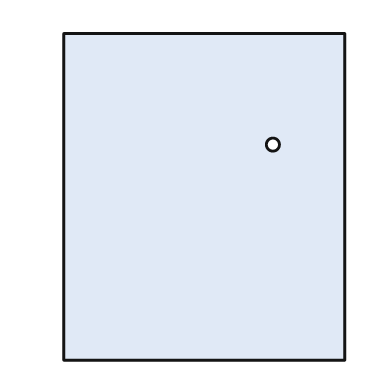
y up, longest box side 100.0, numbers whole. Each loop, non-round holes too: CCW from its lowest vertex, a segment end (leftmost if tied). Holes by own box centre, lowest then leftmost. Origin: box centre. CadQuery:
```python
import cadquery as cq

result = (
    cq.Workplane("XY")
    .moveTo(-43.0, -50.0)
    .lineTo(43.0, -50.0)
    .lineTo(43.0, 50.0)
    .lineTo(-43.0, 50.0)
    .close()
    .moveTo(21.0, 16.0)
    .circle(2.0)
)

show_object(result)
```